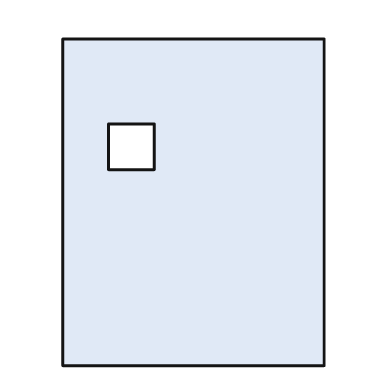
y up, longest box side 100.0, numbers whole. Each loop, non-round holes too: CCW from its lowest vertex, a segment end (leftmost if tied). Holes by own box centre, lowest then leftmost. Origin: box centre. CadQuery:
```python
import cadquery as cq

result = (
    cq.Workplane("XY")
    .moveTo(-40.0, -50.0)
    .lineTo(40.0, -50.0)
    .lineTo(40.0, 50.0)
    .lineTo(-40.0, 50.0)
    .close()
    .moveTo(-26.0, 10.0)
    .lineTo(-12.0, 10.0)
    .lineTo(-12.0, 24.0)
    .lineTo(-26.0, 24.0)
    .close()
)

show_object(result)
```